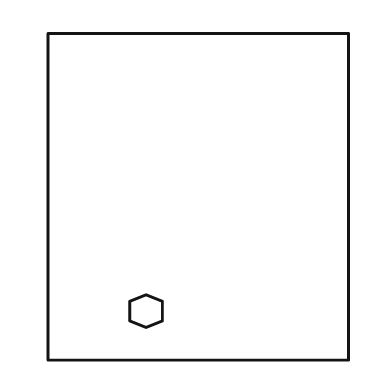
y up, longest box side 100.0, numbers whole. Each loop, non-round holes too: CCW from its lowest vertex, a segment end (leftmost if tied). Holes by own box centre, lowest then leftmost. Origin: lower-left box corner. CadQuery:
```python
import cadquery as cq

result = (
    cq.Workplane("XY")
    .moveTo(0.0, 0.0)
    .lineTo(92.0, 0.0)
    .lineTo(92.0, 100.0)
    .lineTo(0.0, 100.0)
    .close()
    .moveTo(30.0, 10.0)
    .lineTo(35.0, 12.0)
    .lineTo(35.0, 18.0)
    .lineTo(30.0, 20.0)
    .lineTo(25.0, 18.0)
    .lineTo(25.0, 12.0)
    .close()
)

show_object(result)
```